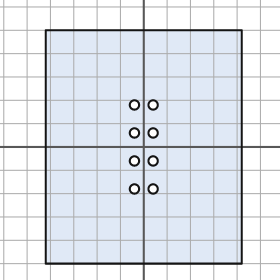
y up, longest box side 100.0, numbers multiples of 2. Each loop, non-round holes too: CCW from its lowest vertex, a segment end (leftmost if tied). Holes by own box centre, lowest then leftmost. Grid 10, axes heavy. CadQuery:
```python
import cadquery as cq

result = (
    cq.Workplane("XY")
    .moveTo(-42.0, -50.0)
    .lineTo(42.0, -50.0)
    .lineTo(42.0, 50.0)
    .lineTo(-42.0, 50.0)
    .close()
    .moveTo(-4.0, -18.0)
    .circle(2.0)
    .moveTo(4.0, -18.0)
    .circle(2.0)
    .moveTo(-4.0, -6.0)
    .circle(2.0)
    .moveTo(4.0, -6.0)
    .circle(2.0)
    .moveTo(-4.0, 6.0)
    .circle(2.0)
    .moveTo(4.0, 6.0)
    .circle(2.0)
    .moveTo(-4.0, 18.0)
    .circle(2.0)
    .moveTo(4.0, 18.0)
    .circle(2.0)
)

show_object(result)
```